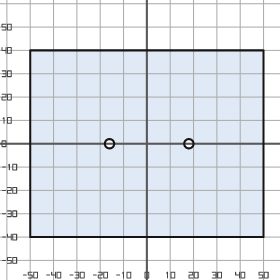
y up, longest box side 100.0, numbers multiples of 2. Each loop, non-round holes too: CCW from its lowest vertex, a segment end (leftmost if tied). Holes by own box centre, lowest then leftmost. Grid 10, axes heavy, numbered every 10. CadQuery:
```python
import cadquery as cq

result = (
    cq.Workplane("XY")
    .moveTo(-50.0, -40.0)
    .lineTo(50.0, -40.0)
    .lineTo(50.0, 40.0)
    .lineTo(-50.0, 40.0)
    .close()
    .moveTo(-16.0, 0.0)
    .circle(2.0)
    .moveTo(18.0, 0.0)
    .circle(2.0)
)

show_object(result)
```